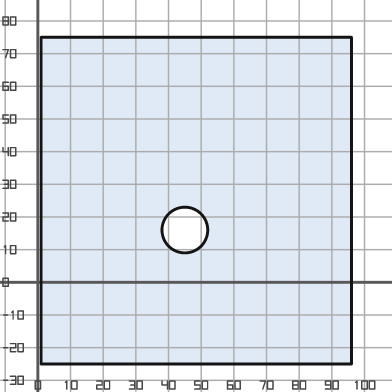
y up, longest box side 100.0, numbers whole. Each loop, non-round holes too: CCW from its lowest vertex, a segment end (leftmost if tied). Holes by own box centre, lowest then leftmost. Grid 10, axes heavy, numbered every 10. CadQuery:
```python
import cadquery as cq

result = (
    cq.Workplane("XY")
    .moveTo(1.0, -25.0)
    .lineTo(96.0, -25.0)
    .lineTo(96.0, 75.0)
    .lineTo(1.0, 75.0)
    .close()
    .moveTo(45.0, 16.0)
    .circle(7.0)
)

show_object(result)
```